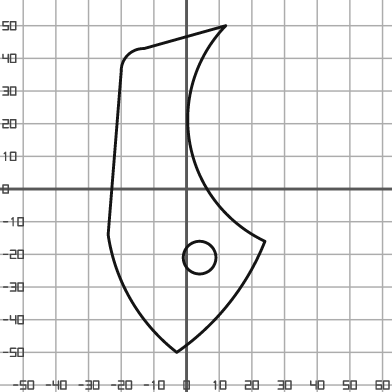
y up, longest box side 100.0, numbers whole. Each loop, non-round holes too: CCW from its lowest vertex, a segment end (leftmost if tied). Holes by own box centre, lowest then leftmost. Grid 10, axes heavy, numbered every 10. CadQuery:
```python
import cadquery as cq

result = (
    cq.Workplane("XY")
    .moveTo(-3.0, -50.0)
    .threePointArc((13.0, -35.0), (24.0, -16.0))
    .threePointArc((1.0, 14.0), (12.0, 50.0))
    .lineTo(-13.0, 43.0)
    .threePointArc((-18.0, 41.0), (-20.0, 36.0))
    .lineTo(-24.0, -14.0)
    .threePointArc((-17.0, -34.0), (-3.0, -50.0))
    .close()
    .moveTo(4.0, -21.0)
    .circle(5.0)
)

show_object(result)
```